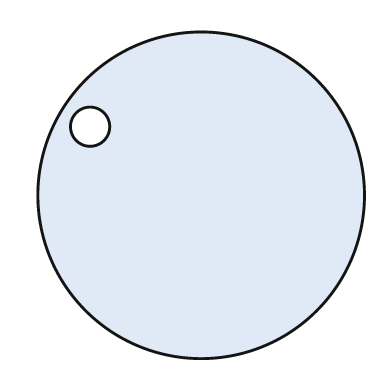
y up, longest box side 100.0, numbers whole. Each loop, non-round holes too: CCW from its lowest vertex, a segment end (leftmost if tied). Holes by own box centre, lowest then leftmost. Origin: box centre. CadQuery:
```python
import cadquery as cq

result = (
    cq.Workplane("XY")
    .moveTo(0.0, 0.0)
    .circle(50.0)
    .moveTo(-34.0, 21.0)
    .circle(6.0)
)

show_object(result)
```